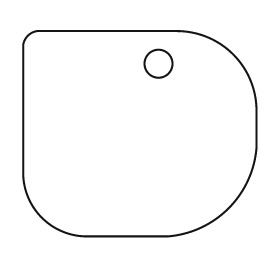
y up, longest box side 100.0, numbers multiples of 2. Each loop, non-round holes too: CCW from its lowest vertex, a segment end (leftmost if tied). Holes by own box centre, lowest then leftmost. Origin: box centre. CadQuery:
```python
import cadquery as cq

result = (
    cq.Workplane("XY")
    .moveTo(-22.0, -44.0)
    .lineTo(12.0, -44.0)
    .threePointArc((38.0, -32.0), (50.0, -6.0))
    .lineTo(50.0, 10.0)
    .threePointArc((40.0, 34.0), (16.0, 44.0))
    .lineTo(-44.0, 44.0)
    .threePointArc((-48.0, 42.0), (-50.0, 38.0))
    .lineTo(-50.0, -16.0)
    .threePointArc((-42.0, -36.0), (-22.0, -44.0))
    .close()
    .moveTo(8.0, 30.0)
    .circle(6.0)
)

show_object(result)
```